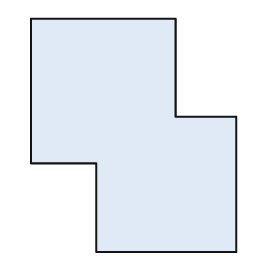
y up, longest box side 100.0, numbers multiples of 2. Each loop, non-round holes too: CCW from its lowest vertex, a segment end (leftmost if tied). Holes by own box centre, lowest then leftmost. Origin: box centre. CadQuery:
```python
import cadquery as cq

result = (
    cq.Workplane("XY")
    .moveTo(-16.0, -50.0)
    .lineTo(44.0, -50.0)
    .lineTo(44.0, 8.0)
    .lineTo(18.0, 8.0)
    .lineTo(18.0, 50.0)
    .lineTo(-44.0, 50.0)
    .lineTo(-44.0, -12.0)
    .lineTo(-16.0, -12.0)
    .close()
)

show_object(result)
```